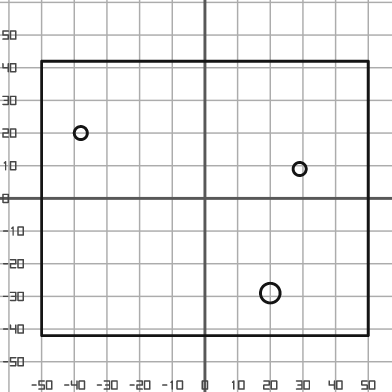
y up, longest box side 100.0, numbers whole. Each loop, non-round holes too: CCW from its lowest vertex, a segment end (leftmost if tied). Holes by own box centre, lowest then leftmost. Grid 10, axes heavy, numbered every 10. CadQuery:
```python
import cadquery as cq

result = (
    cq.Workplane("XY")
    .moveTo(-50.0, -42.0)
    .lineTo(50.0, -42.0)
    .lineTo(50.0, 42.0)
    .lineTo(-50.0, 42.0)
    .close()
    .moveTo(20.0, -29.0)
    .circle(3.0)
    .moveTo(29.0, 9.0)
    .circle(2.0)
    .moveTo(-38.0, 20.0)
    .circle(2.0)
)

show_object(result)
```